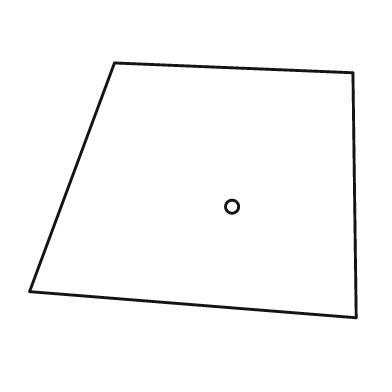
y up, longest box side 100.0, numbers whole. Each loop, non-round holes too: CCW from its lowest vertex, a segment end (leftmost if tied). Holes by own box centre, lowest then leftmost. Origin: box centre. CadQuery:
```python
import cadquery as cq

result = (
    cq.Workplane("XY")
    .moveTo(50.0, -39.0)
    .lineTo(49.0, 36.0)
    .lineTo(-24.0, 39.0)
    .lineTo(-50.0, -31.0)
    .close()
    .moveTo(12.0, -5.0)
    .circle(2.0)
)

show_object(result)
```